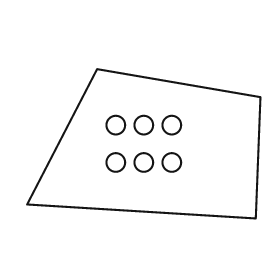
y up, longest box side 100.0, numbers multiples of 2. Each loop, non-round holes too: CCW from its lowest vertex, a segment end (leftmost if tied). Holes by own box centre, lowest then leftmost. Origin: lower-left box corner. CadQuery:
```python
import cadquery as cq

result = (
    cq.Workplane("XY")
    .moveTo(98.0, 0.0)
    .lineTo(100.0, 52.0)
    .lineTo(30.0, 64.0)
    .lineTo(0.0, 6.0)
    .close()
    .moveTo(38.0, 24.0)
    .circle(4.0)
    .moveTo(50.0, 24.0)
    .circle(4.0)
    .moveTo(62.0, 24.0)
    .circle(4.0)
    .moveTo(38.0, 40.0)
    .circle(4.0)
    .moveTo(50.0, 40.0)
    .circle(4.0)
    .moveTo(62.0, 40.0)
    .circle(4.0)
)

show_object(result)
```